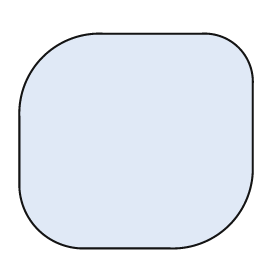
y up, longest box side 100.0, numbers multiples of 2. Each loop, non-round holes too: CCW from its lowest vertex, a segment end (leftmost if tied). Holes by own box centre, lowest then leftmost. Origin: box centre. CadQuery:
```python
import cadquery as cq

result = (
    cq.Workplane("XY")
    .moveTo(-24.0, -46.0)
    .lineTo(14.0, -46.0)
    .threePointArc((40.0, -36.0), (50.0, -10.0))
    .lineTo(50.0, 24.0)
    .threePointArc((44.0, 40.0), (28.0, 46.0))
    .lineTo(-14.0, 46.0)
    .threePointArc((-40.0, 36.0), (-50.0, 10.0))
    .lineTo(-50.0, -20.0)
    .threePointArc((-42.0, -38.0), (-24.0, -46.0))
    .close()
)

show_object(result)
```